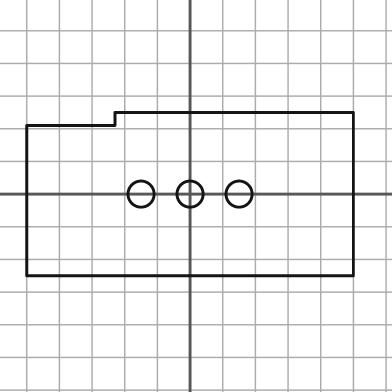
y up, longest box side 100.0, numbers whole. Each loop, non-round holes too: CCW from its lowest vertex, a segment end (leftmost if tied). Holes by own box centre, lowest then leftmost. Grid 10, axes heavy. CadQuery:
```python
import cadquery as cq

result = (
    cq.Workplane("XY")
    .moveTo(-50.0, -25.0)
    .lineTo(50.0, -25.0)
    .lineTo(50.0, 25.0)
    .lineTo(-23.0, 25.0)
    .lineTo(-23.0, 21.0)
    .lineTo(-50.0, 21.0)
    .close()
    .moveTo(-15.0, 0.0)
    .circle(4.0)
    .moveTo(0.0, 0.0)
    .circle(4.0)
    .moveTo(15.0, 0.0)
    .circle(4.0)
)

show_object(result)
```